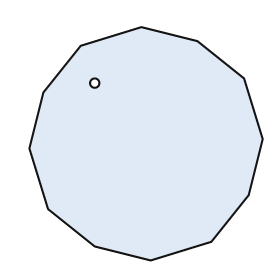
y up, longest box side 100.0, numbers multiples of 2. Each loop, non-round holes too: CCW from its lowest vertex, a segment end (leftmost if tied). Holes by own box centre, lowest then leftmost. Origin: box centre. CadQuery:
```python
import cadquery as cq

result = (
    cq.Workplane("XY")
    .moveTo(2.0, -50.0)
    .lineTo(28.0, -42.0)
    .lineTo(44.0, -22.0)
    .lineTo(50.0, 2.0)
    .lineTo(42.0, 28.0)
    .lineTo(22.0, 44.0)
    .lineTo(-2.0, 50.0)
    .lineTo(-28.0, 42.0)
    .lineTo(-44.0, 22.0)
    .lineTo(-50.0, -2.0)
    .lineTo(-42.0, -28.0)
    .lineTo(-22.0, -44.0)
    .close()
    .moveTo(-22.0, 26.0)
    .circle(2.0)
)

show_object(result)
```